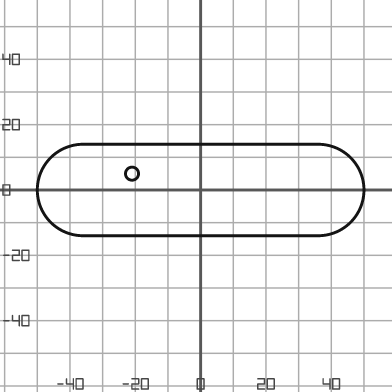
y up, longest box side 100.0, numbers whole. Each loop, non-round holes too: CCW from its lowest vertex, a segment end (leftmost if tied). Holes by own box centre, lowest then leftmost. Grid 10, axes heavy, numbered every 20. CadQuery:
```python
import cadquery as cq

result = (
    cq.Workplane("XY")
    .moveTo(-36.0, -14.0)
    .lineTo(36.0, -14.0)
    .threePointArc((50.0, 0.0), (36.0, 14.0))
    .lineTo(-36.0, 14.0)
    .threePointArc((-50.0, 0.0), (-36.0, -14.0))
    .close()
    .moveTo(-21.0, 5.0)
    .circle(2.0)
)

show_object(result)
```